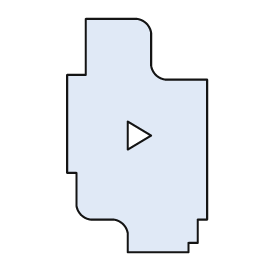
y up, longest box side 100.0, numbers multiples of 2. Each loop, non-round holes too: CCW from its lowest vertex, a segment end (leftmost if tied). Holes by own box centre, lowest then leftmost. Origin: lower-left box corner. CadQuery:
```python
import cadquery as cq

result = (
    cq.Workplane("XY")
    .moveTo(26.0, 0.0)
    .lineTo(52.0, 0.0)
    .lineTo(52.0, 4.0)
    .lineTo(56.0, 4.0)
    .lineTo(56.0, 14.0)
    .lineTo(60.0, 14.0)
    .lineTo(60.0, 74.0)
    .lineTo(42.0, 74.0)
    .threePointArc((38.0, 76.0), (36.0, 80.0))
    .lineTo(36.0, 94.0)
    .threePointArc((34.0, 98.0), (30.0, 100.0))
    .lineTo(8.0, 100.0)
    .lineTo(8.0, 76.0)
    .lineTo(0.0, 76.0)
    .lineTo(0.0, 34.0)
    .lineTo(4.0, 34.0)
    .lineTo(4.0, 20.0)
    .threePointArc((6.0, 16.0), (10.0, 14.0))
    .lineTo(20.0, 14.0)
    .threePointArc((24.0, 12.0), (26.0, 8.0))
    .close()
    .moveTo(26.0, 44.0)
    .lineTo(36.0, 50.0)
    .lineTo(26.0, 56.0)
    .close()
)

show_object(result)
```